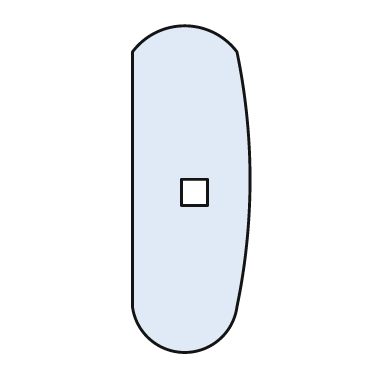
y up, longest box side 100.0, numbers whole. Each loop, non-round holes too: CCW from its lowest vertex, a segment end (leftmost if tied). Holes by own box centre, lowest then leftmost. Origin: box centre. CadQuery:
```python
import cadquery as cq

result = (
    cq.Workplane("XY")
    .moveTo(-18.0, -36.0)
    .threePointArc((-2.0, -50.0), (14.0, -36.0))
    .threePointArc((18.0, 3.0), (14.0, 42.0))
    .threePointArc((-2.0, 50.0), (-18.0, 42.0))
    .close()
    .moveTo(-3.0, -5.0)
    .lineTo(5.0, -5.0)
    .lineTo(5.0, 3.0)
    .lineTo(-3.0, 3.0)
    .close()
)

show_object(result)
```